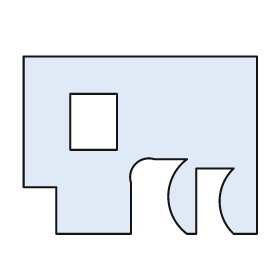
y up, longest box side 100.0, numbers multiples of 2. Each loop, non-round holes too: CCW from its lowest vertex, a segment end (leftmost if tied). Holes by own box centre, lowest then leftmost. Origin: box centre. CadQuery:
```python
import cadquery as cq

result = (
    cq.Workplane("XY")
    .moveTo(-36.0, -38.0)
    .lineTo(-4.0, -38.0)
    .lineTo(-4.0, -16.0)
    .threePointArc((-2.0, -8.0), (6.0, -6.0))
    .lineTo(20.0, -6.0)
    .threePointArc((12.0, -22.0), (20.0, -38.0))
    .lineTo(24.0, -38.0)
    .lineTo(24.0, -10.0)
    .lineTo(40.0, -10.0)
    .threePointArc((34.0, -24.0), (40.0, -38.0))
    .lineTo(50.0, -38.0)
    .lineTo(50.0, 38.0)
    .lineTo(-50.0, 38.0)
    .lineTo(-50.0, -18.0)
    .lineTo(-36.0, -18.0)
    .close()
    .moveTo(-30.0, -2.0)
    .lineTo(-10.0, -2.0)
    .lineTo(-10.0, 22.0)
    .lineTo(-30.0, 22.0)
    .close()
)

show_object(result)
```